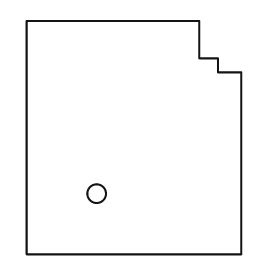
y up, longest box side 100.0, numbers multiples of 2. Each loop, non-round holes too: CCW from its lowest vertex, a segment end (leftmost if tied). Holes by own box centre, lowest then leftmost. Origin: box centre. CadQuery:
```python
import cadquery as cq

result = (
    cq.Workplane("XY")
    .moveTo(-46.0, -50.0)
    .lineTo(46.0, -50.0)
    .lineTo(46.0, 28.0)
    .lineTo(36.0, 28.0)
    .lineTo(36.0, 34.0)
    .lineTo(28.0, 34.0)
    .lineTo(28.0, 50.0)
    .lineTo(-46.0, 50.0)
    .close()
    .moveTo(-16.0, -24.0)
    .circle(4.0)
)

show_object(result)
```